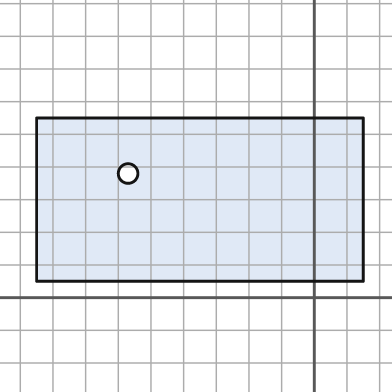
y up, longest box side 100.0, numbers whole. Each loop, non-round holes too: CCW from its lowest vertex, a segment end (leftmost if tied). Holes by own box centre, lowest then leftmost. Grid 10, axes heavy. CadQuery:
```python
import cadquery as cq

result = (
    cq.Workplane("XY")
    .moveTo(-85.0, 5.0)
    .lineTo(15.0, 5.0)
    .lineTo(15.0, 55.0)
    .lineTo(-85.0, 55.0)
    .close()
    .moveTo(-57.0, 38.0)
    .circle(3.0)
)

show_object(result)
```